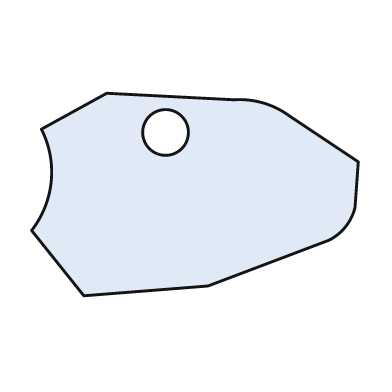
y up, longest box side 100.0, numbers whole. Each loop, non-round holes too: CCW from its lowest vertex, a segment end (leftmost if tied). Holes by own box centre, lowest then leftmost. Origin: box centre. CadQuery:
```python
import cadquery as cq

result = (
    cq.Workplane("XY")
    .moveTo(-34.0, -31.0)
    .lineTo(4.0, -28.0)
    .lineTo(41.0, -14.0)
    .threePointArc((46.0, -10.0), (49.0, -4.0))
    .lineTo(50.0, 10.0)
    .lineTo(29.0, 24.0)
    .threePointArc((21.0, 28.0), (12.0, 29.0))
    .lineTo(-27.0, 31.0)
    .lineTo(-47.0, 20.0)
    .threePointArc((-44.0, 4.0), (-50.0, -11.0))
    .close()
    .moveTo(-9.0, 19.0)
    .circle(7.0)
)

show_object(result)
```